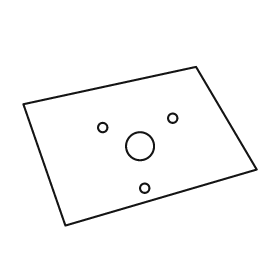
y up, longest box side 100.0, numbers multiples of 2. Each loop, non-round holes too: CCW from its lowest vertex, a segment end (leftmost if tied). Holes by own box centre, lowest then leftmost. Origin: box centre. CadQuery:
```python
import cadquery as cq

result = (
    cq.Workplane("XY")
    .moveTo(-32.0, -34.0)
    .lineTo(50.0, -10.0)
    .lineTo(24.0, 34.0)
    .lineTo(-50.0, 18.0)
    .close()
    .moveTo(2.0, -18.0)
    .circle(2.0)
    .moveTo(0.0, 0.0)
    .circle(6.0)
    .moveTo(-16.0, 8.0)
    .circle(2.0)
    .moveTo(14.0, 12.0)
    .circle(2.0)
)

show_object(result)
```